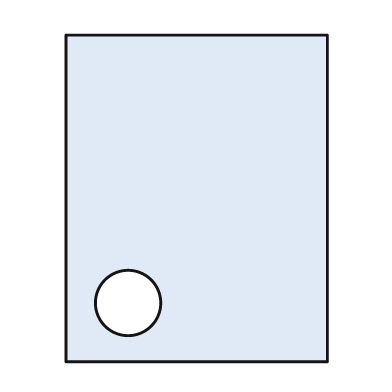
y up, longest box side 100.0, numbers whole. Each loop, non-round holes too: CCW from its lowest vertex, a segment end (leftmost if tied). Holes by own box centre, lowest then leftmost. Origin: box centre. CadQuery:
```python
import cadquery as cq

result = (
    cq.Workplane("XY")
    .moveTo(-40.0, -50.0)
    .lineTo(40.0, -50.0)
    .lineTo(40.0, 50.0)
    .lineTo(-40.0, 50.0)
    .close()
    .moveTo(-21.0, -32.0)
    .circle(10.0)
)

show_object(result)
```